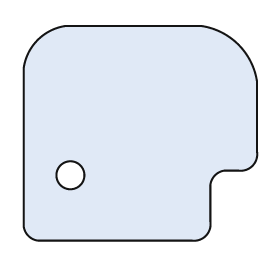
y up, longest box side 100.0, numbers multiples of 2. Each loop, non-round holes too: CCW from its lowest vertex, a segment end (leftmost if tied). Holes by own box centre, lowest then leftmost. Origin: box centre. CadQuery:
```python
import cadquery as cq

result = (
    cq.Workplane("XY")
    .moveTo(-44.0, -46.0)
    .lineTo(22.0, -46.0)
    .threePointArc((28.0, -44.0), (30.0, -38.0))
    .lineTo(30.0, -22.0)
    .threePointArc((32.0, -18.0), (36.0, -16.0))
    .lineTo(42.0, -16.0)
    .threePointArc((48.0, -14.0), (50.0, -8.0))
    .lineTo(50.0, 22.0)
    .threePointArc((42.0, 38.0), (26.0, 46.0))
    .lineTo(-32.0, 46.0)
    .threePointArc((-44.0, 40.0), (-50.0, 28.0))
    .lineTo(-50.0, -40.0)
    .threePointArc((-48.0, -44.0), (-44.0, -46.0))
    .close()
    .moveTo(-30.0, -18.0)
    .circle(6.0)
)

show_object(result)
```